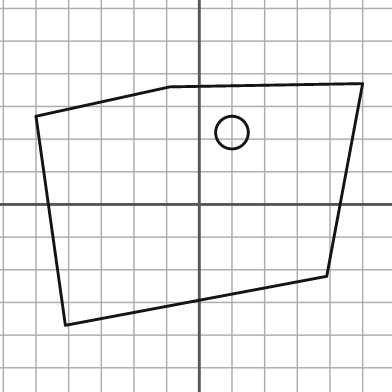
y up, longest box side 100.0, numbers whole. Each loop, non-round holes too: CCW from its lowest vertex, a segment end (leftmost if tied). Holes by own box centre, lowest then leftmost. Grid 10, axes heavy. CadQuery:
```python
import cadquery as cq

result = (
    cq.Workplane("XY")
    .moveTo(-41.0, -37.0)
    .lineTo(39.0, -22.0)
    .lineTo(50.0, 37.0)
    .lineTo(-9.0, 36.0)
    .lineTo(-50.0, 27.0)
    .close()
    .moveTo(10.0, 22.0)
    .circle(5.0)
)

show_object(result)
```